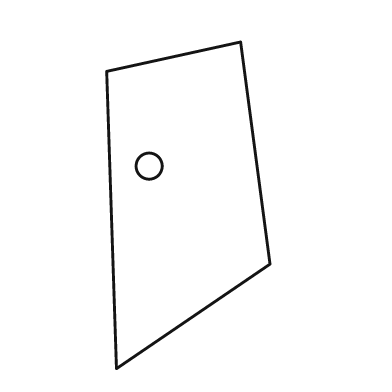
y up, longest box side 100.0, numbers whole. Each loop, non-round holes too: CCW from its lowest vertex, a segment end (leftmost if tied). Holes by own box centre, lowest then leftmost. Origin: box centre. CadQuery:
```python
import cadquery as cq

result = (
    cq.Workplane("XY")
    .moveTo(-22.0, -50.0)
    .lineTo(25.0, -18.0)
    .lineTo(16.0, 50.0)
    .lineTo(-25.0, 41.0)
    .close()
    .moveTo(-12.0, 12.0)
    .circle(4.0)
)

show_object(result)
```